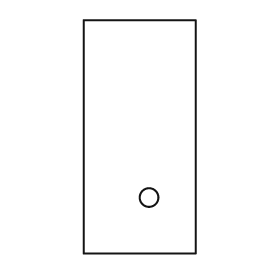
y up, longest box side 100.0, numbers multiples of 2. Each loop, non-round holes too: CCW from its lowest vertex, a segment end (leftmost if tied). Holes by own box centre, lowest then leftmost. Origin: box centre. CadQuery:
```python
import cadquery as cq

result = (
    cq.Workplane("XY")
    .moveTo(-24.0, -50.0)
    .lineTo(24.0, -50.0)
    .lineTo(24.0, 50.0)
    .lineTo(-24.0, 50.0)
    .close()
    .moveTo(4.0, -26.0)
    .circle(4.0)
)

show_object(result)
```